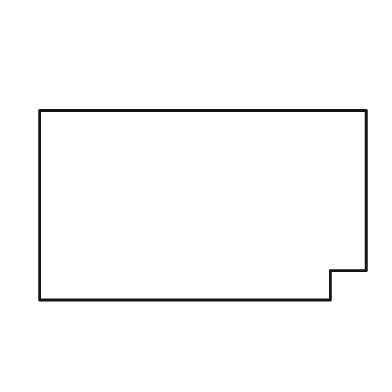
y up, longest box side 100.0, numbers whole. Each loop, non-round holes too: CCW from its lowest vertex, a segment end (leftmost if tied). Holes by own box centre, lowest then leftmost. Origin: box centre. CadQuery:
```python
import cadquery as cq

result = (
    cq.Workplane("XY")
    .moveTo(-50.0, -29.0)
    .lineTo(39.0, -29.0)
    .lineTo(39.0, -20.0)
    .lineTo(50.0, -20.0)
    .lineTo(50.0, 29.0)
    .lineTo(-50.0, 29.0)
    .close()
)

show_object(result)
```